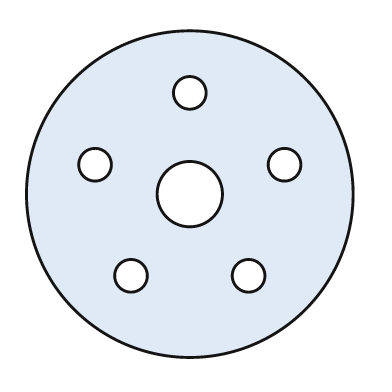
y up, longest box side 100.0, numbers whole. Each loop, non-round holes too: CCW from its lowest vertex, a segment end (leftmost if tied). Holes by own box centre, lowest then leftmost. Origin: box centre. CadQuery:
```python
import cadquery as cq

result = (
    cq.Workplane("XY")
    .moveTo(0.0, 0.0)
    .circle(50.0)
    .moveTo(-18.0, -25.0)
    .circle(5.0)
    .moveTo(18.0, -25.0)
    .circle(5.0)
    .moveTo(0.0, 0.0)
    .circle(10.0)
    .moveTo(-29.0, 9.0)
    .circle(5.0)
    .moveTo(29.0, 9.0)
    .circle(5.0)
    .moveTo(0.0, 31.0)
    .circle(5.0)
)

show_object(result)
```